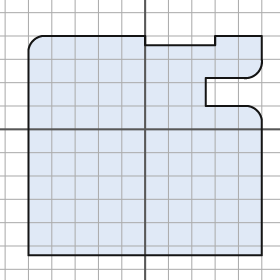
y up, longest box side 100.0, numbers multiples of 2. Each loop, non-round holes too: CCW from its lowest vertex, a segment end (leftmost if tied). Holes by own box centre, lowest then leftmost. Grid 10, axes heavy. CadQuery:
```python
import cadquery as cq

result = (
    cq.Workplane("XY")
    .moveTo(-50.0, -54.0)
    .lineTo(50.0, -54.0)
    .lineTo(50.0, 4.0)
    .threePointArc((48.0, 8.0), (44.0, 10.0))
    .lineTo(26.0, 10.0)
    .lineTo(26.0, 22.0)
    .lineTo(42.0, 22.0)
    .threePointArc((48.0, 24.0), (50.0, 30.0))
    .lineTo(50.0, 40.0)
    .lineTo(30.0, 40.0)
    .lineTo(30.0, 36.0)
    .lineTo(0.0, 36.0)
    .lineTo(0.0, 40.0)
    .lineTo(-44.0, 40.0)
    .threePointArc((-48.0, 38.0), (-50.0, 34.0))
    .close()
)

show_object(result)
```